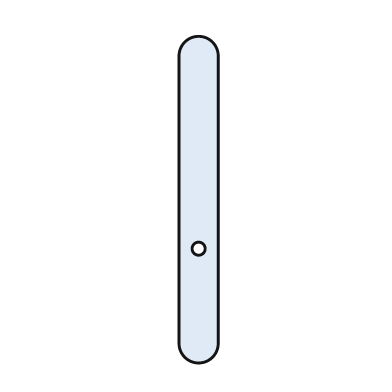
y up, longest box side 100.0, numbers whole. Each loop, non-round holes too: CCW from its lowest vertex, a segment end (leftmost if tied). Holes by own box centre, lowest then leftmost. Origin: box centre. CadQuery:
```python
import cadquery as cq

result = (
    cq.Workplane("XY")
    .moveTo(-6.0, -44.0)
    .threePointArc((0.0, -50.0), (6.0, -44.0))
    .lineTo(6.0, 44.0)
    .threePointArc((0.0, 50.0), (-6.0, 44.0))
    .close()
    .moveTo(0.0, -15.0)
    .circle(2.0)
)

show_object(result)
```